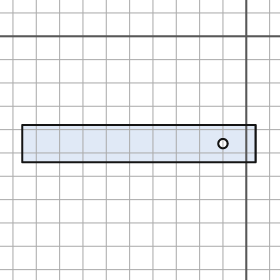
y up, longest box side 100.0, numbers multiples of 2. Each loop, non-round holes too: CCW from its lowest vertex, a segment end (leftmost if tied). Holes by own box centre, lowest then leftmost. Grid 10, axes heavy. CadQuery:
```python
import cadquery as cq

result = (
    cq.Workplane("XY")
    .moveTo(-96.0, -54.0)
    .lineTo(4.0, -54.0)
    .lineTo(4.0, -38.0)
    .lineTo(-96.0, -38.0)
    .close()
    .moveTo(-10.0, -46.0)
    .circle(2.0)
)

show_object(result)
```